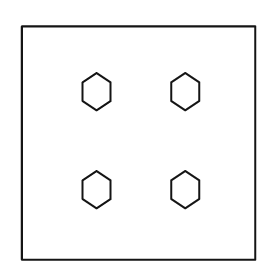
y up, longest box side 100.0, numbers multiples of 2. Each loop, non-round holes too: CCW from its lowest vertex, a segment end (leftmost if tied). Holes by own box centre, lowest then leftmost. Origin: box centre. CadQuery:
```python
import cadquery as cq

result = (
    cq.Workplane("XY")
    .moveTo(-50.0, -50.0)
    .lineTo(50.0, -50.0)
    .lineTo(50.0, 50.0)
    .lineTo(-50.0, 50.0)
    .close()
    .moveTo(-18.0, -28.0)
    .lineTo(-12.0, -24.0)
    .lineTo(-12.0, -16.0)
    .lineTo(-18.0, -12.0)
    .lineTo(-24.0, -16.0)
    .lineTo(-24.0, -24.0)
    .close()
    .moveTo(20.0, -28.0)
    .lineTo(26.0, -24.0)
    .lineTo(26.0, -16.0)
    .lineTo(20.0, -12.0)
    .lineTo(14.0, -16.0)
    .lineTo(14.0, -24.0)
    .close()
    .moveTo(-18.0, 14.0)
    .lineTo(-12.0, 18.0)
    .lineTo(-12.0, 26.0)
    .lineTo(-18.0, 30.0)
    .lineTo(-24.0, 26.0)
    .lineTo(-24.0, 18.0)
    .close()
    .moveTo(20.0, 14.0)
    .lineTo(26.0, 18.0)
    .lineTo(26.0, 26.0)
    .lineTo(20.0, 30.0)
    .lineTo(14.0, 26.0)
    .lineTo(14.0, 18.0)
    .close()
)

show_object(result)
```